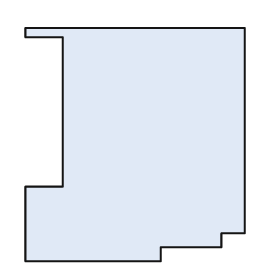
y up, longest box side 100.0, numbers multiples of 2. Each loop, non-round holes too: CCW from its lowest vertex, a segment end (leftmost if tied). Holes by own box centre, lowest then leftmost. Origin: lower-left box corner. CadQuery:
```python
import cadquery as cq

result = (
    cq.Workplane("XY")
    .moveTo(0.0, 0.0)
    .lineTo(58.0, 0.0)
    .lineTo(58.0, 6.0)
    .lineTo(84.0, 6.0)
    .lineTo(84.0, 12.0)
    .lineTo(94.0, 12.0)
    .lineTo(94.0, 100.0)
    .lineTo(0.0, 100.0)
    .lineTo(0.0, 96.0)
    .lineTo(16.0, 96.0)
    .lineTo(16.0, 32.0)
    .lineTo(0.0, 32.0)
    .close()
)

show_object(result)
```